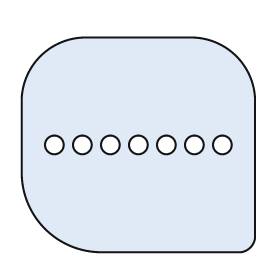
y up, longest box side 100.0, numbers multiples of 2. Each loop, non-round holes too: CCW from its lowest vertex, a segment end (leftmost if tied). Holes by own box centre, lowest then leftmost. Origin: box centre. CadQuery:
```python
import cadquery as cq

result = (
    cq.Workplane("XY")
    .moveTo(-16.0, -46.0)
    .lineTo(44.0, -46.0)
    .threePointArc((48.0, -44.0), (50.0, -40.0))
    .lineTo(50.0, 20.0)
    .threePointArc((42.0, 38.0), (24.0, 46.0))
    .lineTo(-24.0, 46.0)
    .threePointArc((-42.0, 38.0), (-50.0, 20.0))
    .lineTo(-50.0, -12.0)
    .threePointArc((-40.0, -36.0), (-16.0, -46.0))
    .close()
    .moveTo(-36.0, 0.0)
    .circle(4.0)
    .moveTo(-24.0, 0.0)
    .circle(4.0)
    .moveTo(-12.0, 0.0)
    .circle(4.0)
    .moveTo(0.0, 0.0)
    .circle(4.0)
    .moveTo(12.0, 0.0)
    .circle(4.0)
    .moveTo(24.0, 0.0)
    .circle(4.0)
    .moveTo(36.0, 0.0)
    .circle(4.0)
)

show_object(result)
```